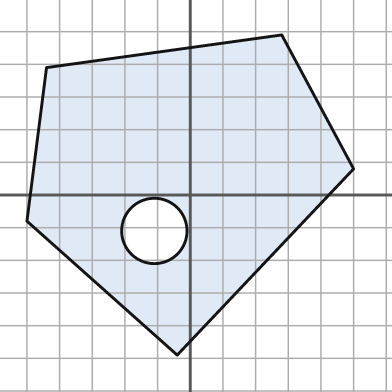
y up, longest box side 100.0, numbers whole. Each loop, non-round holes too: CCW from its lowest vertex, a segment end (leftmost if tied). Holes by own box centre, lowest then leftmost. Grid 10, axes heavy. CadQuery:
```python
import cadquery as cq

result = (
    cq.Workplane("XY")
    .moveTo(-4.0, -49.0)
    .lineTo(50.0, 8.0)
    .lineTo(28.0, 49.0)
    .lineTo(-44.0, 39.0)
    .lineTo(-50.0, -8.0)
    .close()
    .moveTo(-11.0, -11.0)
    .circle(10.0)
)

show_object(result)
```